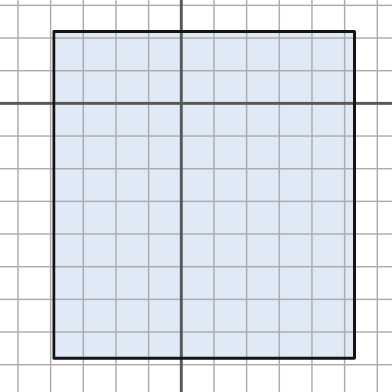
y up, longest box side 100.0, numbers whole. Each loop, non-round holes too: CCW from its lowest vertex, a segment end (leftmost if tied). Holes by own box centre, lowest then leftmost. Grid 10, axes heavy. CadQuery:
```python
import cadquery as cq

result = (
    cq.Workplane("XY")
    .moveTo(-39.0, -78.0)
    .lineTo(53.0, -78.0)
    .lineTo(53.0, 22.0)
    .lineTo(-39.0, 22.0)
    .close()
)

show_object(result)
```